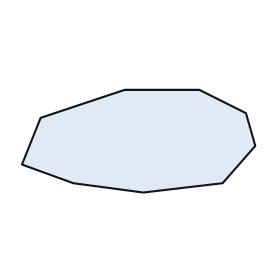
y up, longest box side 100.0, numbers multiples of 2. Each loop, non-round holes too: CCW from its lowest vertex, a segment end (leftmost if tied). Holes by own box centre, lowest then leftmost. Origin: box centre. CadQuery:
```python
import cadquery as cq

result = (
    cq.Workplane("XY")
    .moveTo(2.0, -22.0)
    .lineTo(36.0, -18.0)
    .lineTo(50.0, -2.0)
    .lineTo(46.0, 12.0)
    .lineTo(26.0, 22.0)
    .lineTo(-6.0, 22.0)
    .lineTo(-42.0, 10.0)
    .lineTo(-50.0, -10.0)
    .lineTo(-28.0, -18.0)
    .close()
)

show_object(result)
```